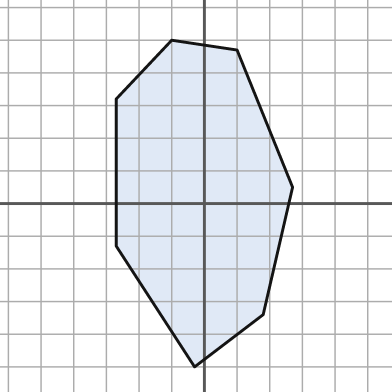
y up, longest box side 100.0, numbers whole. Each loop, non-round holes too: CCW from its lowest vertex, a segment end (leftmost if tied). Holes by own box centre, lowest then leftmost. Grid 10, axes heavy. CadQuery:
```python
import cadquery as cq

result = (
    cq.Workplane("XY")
    .moveTo(-3.0, -50.0)
    .lineTo(18.0, -34.0)
    .lineTo(27.0, 5.0)
    .lineTo(10.0, 47.0)
    .lineTo(-10.0, 50.0)
    .lineTo(-27.0, 32.0)
    .lineTo(-27.0, -13.0)
    .close()
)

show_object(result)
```